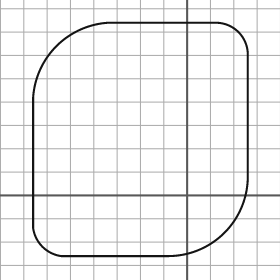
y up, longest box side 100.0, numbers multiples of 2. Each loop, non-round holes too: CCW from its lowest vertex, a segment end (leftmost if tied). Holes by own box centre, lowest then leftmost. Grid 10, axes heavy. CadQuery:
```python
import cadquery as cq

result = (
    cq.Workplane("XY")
    .moveTo(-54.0, -26.0)
    .lineTo(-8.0, -26.0)
    .threePointArc((16.0, -16.0), (26.0, 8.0))
    .lineTo(26.0, 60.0)
    .threePointArc((22.0, 70.0), (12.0, 74.0))
    .lineTo(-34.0, 74.0)
    .threePointArc((-56.0, 64.0), (-66.0, 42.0))
    .lineTo(-66.0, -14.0)
    .threePointArc((-62.0, -22.0), (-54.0, -26.0))
    .close()
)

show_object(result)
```